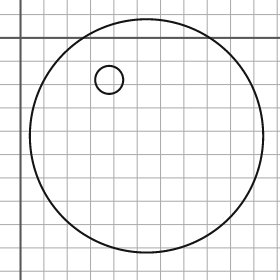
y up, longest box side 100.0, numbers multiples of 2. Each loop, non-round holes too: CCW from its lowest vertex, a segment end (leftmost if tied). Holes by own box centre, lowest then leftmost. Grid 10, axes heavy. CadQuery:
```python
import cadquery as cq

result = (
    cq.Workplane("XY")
    .moveTo(54.0, -42.0)
    .circle(50.0)
    .moveTo(38.0, -18.0)
    .circle(6.0)
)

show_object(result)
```